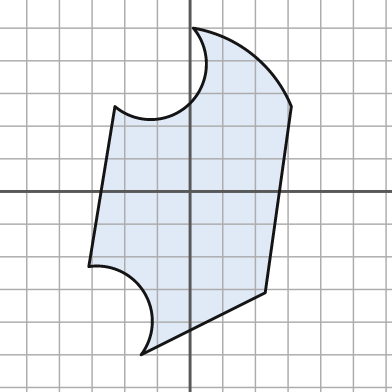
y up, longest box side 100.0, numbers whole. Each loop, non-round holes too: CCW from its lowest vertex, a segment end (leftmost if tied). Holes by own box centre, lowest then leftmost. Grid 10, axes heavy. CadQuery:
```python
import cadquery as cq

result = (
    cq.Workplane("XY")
    .moveTo(-15.0, -50.0)
    .lineTo(23.0, -31.0)
    .lineTo(31.0, 26.0)
    .threePointArc((19.0, 42.0), (1.0, 50.0))
    .threePointArc((0.0, 27.0), (-23.0, 26.0))
    .lineTo(-31.0, -23.0)
    .threePointArc((-14.0, -31.0), (-15.0, -50.0))
    .close()
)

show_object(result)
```